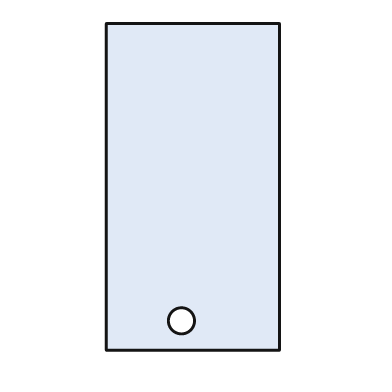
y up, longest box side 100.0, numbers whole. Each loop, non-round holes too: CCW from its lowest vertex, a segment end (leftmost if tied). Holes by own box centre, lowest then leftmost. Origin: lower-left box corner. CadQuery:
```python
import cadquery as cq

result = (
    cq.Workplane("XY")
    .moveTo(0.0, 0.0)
    .lineTo(53.0, 0.0)
    .lineTo(53.0, 100.0)
    .lineTo(0.0, 100.0)
    .close()
    .moveTo(23.0, 9.0)
    .circle(4.0)
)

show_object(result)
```